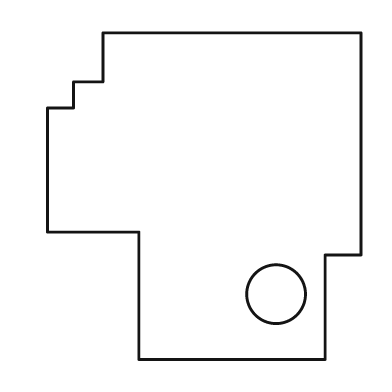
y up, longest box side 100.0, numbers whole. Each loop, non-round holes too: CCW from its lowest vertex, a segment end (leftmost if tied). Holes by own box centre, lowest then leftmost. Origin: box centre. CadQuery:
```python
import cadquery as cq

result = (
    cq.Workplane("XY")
    .moveTo(-20.0, -50.0)
    .lineTo(37.0, -50.0)
    .lineTo(37.0, -18.0)
    .lineTo(48.0, -18.0)
    .lineTo(48.0, 50.0)
    .lineTo(-31.0, 50.0)
    .lineTo(-31.0, 35.0)
    .lineTo(-40.0, 35.0)
    .lineTo(-40.0, 27.0)
    .lineTo(-48.0, 27.0)
    .lineTo(-48.0, -11.0)
    .lineTo(-20.0, -11.0)
    .close()
    .moveTo(22.0, -30.0)
    .circle(9.0)
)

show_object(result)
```